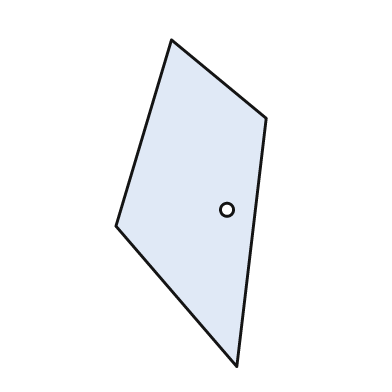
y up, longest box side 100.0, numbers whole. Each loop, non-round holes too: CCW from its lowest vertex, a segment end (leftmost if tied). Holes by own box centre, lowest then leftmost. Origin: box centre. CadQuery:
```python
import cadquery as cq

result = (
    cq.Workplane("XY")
    .moveTo(14.0, -50.0)
    .lineTo(23.0, 26.0)
    .lineTo(-6.0, 50.0)
    .lineTo(-23.0, -7.0)
    .close()
    .moveTo(11.0, -2.0)
    .circle(2.0)
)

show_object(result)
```